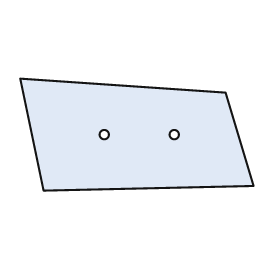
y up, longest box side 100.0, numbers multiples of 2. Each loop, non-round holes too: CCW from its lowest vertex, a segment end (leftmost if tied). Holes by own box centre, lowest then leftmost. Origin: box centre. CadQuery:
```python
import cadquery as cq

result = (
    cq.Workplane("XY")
    .moveTo(-40.0, -24.0)
    .lineTo(50.0, -22.0)
    .lineTo(38.0, 18.0)
    .lineTo(-50.0, 24.0)
    .close()
    .moveTo(-14.0, 0.0)
    .circle(2.0)
    .moveTo(16.0, 0.0)
    .circle(2.0)
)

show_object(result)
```